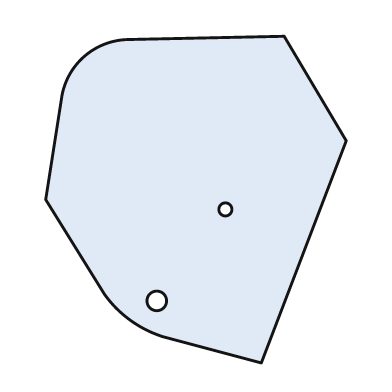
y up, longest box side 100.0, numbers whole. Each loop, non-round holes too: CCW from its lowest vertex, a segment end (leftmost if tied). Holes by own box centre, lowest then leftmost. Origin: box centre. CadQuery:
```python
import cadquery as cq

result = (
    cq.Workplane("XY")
    .moveTo(20.0, -50.0)
    .lineTo(46.0, 18.0)
    .lineTo(27.0, 50.0)
    .lineTo(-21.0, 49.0)
    .threePointArc((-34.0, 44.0), (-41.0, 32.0))
    .lineTo(-46.0, 0.0)
    .lineTo(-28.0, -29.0)
    .threePointArc((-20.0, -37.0), (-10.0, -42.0))
    .close()
    .moveTo(-12.0, -31.0)
    .circle(3.0)
    .moveTo(9.0, -3.0)
    .circle(2.0)
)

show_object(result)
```